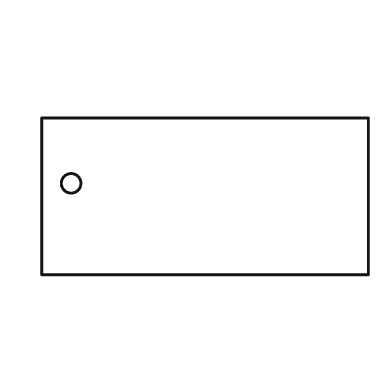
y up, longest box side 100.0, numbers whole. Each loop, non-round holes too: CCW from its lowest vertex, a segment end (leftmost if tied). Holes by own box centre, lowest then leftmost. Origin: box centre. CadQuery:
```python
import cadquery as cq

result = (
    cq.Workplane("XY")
    .moveTo(-50.0, -24.0)
    .lineTo(50.0, -24.0)
    .lineTo(50.0, 24.0)
    .lineTo(-50.0, 24.0)
    .close()
    .moveTo(-41.0, 4.0)
    .circle(3.0)
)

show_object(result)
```